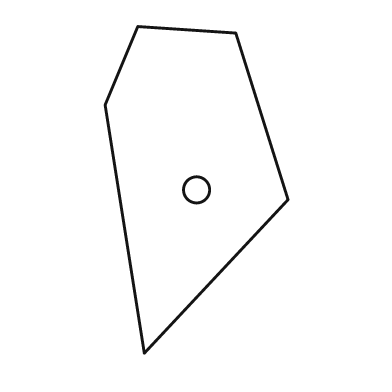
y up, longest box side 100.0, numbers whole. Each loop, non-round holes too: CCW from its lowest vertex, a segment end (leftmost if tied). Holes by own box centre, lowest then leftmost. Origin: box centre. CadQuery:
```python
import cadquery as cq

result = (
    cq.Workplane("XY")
    .moveTo(-16.0, -50.0)
    .lineTo(28.0, -3.0)
    .lineTo(12.0, 48.0)
    .lineTo(-18.0, 50.0)
    .lineTo(-28.0, 26.0)
    .close()
    .moveTo(0.0, 0.0)
    .circle(4.0)
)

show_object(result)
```